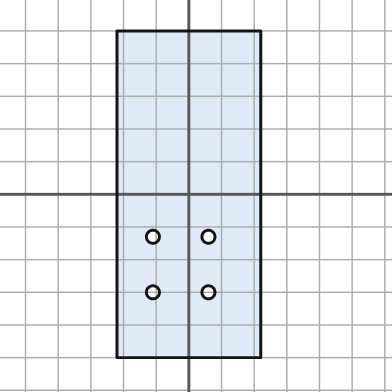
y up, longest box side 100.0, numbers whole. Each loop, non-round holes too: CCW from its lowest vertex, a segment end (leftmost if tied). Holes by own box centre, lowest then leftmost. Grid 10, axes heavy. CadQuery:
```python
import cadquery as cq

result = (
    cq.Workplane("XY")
    .moveTo(-22.0, -50.0)
    .lineTo(22.0, -50.0)
    .lineTo(22.0, 50.0)
    .lineTo(-22.0, 50.0)
    .close()
    .moveTo(-11.0, -30.0)
    .circle(2.0)
    .moveTo(6.0, -30.0)
    .circle(2.0)
    .moveTo(-11.0, -13.0)
    .circle(2.0)
    .moveTo(6.0, -13.0)
    .circle(2.0)
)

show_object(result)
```